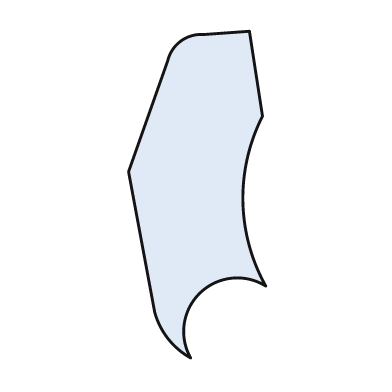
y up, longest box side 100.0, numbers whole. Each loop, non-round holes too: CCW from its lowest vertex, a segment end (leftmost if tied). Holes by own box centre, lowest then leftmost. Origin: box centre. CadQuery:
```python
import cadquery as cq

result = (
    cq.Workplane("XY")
    .moveTo(-2.0, -50.0)
    .threePointArc((1.0, -30.0), (21.0, -28.0))
    .threePointArc((14.0, -2.0), (20.0, 24.0))
    .lineTo(16.0, 50.0)
    .lineTo(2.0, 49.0)
    .threePointArc((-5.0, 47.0), (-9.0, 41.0))
    .lineTo(-21.0, 7.0)
    .lineTo(-13.0, -36.0)
    .threePointArc((-9.0, -44.0), (-2.0, -50.0))
    .close()
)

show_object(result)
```